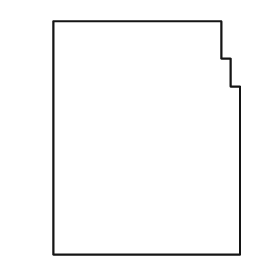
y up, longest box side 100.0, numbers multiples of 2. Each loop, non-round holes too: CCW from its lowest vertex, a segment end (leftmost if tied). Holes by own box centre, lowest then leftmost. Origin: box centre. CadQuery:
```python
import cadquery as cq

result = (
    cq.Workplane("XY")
    .moveTo(-40.0, -50.0)
    .lineTo(40.0, -50.0)
    .lineTo(40.0, 22.0)
    .lineTo(36.0, 22.0)
    .lineTo(36.0, 34.0)
    .lineTo(32.0, 34.0)
    .lineTo(32.0, 50.0)
    .lineTo(-40.0, 50.0)
    .close()
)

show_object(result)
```